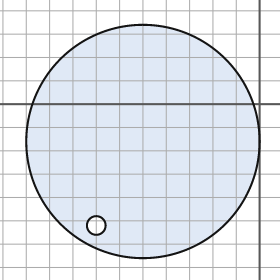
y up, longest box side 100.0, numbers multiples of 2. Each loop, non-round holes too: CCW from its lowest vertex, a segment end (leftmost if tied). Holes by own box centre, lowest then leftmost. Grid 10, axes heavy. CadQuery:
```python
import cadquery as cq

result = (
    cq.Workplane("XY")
    .moveTo(-50.0, -16.0)
    .circle(50.0)
    .moveTo(-70.0, -52.0)
    .circle(4.0)
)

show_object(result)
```